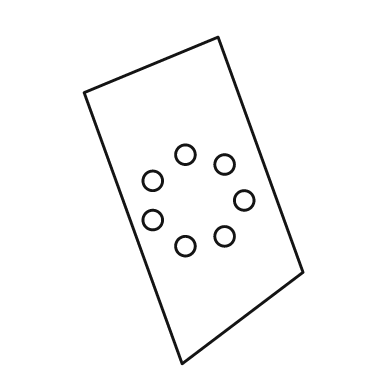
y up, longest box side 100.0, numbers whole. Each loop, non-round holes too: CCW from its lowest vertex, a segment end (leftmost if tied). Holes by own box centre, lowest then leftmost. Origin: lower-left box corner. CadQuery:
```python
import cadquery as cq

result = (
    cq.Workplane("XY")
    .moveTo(30.0, 0.0)
    .lineTo(67.0, 28.0)
    .lineTo(41.0, 100.0)
    .lineTo(0.0, 83.0)
    .close()
    .moveTo(31.0, 36.0)
    .circle(3.0)
    .moveTo(43.0, 39.0)
    .circle(3.0)
    .moveTo(21.0, 44.0)
    .circle(3.0)
    .moveTo(49.0, 50.0)
    .circle(3.0)
    .moveTo(21.0, 56.0)
    .circle(3.0)
    .moveTo(43.0, 61.0)
    .circle(3.0)
    .moveTo(31.0, 64.0)
    .circle(3.0)
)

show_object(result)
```